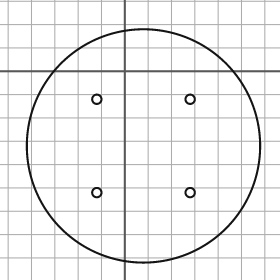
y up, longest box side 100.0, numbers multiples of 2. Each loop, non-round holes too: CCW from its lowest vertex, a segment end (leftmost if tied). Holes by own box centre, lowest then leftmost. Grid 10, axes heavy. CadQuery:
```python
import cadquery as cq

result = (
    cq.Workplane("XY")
    .moveTo(8.0, -32.0)
    .circle(50.0)
    .moveTo(-12.0, -52.0)
    .circle(2.0)
    .moveTo(28.0, -52.0)
    .circle(2.0)
    .moveTo(-12.0, -12.0)
    .circle(2.0)
    .moveTo(28.0, -12.0)
    .circle(2.0)
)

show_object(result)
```